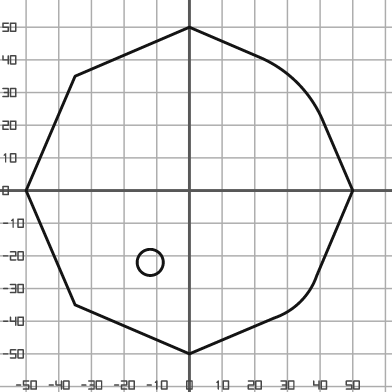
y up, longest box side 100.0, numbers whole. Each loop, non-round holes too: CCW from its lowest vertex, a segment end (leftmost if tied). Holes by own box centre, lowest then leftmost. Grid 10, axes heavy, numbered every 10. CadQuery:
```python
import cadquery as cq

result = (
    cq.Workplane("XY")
    .moveTo(0.0, -50.0)
    .lineTo(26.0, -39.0)
    .threePointArc((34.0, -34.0), (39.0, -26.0))
    .lineTo(50.0, 0.0)
    .lineTo(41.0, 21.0)
    .threePointArc((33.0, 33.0), (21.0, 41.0))
    .lineTo(0.0, 50.0)
    .lineTo(-35.0, 35.0)
    .lineTo(-50.0, 0.0)
    .lineTo(-35.0, -35.0)
    .close()
    .moveTo(-12.0, -22.0)
    .circle(4.0)
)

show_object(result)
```